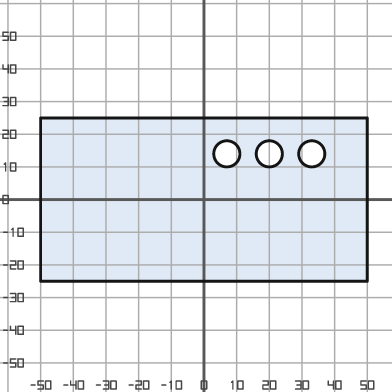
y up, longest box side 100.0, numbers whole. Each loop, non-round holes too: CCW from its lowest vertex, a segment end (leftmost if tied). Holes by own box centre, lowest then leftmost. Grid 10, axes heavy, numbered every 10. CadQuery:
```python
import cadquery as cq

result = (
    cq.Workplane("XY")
    .moveTo(-50.0, -25.0)
    .lineTo(50.0, -25.0)
    .lineTo(50.0, 25.0)
    .lineTo(-50.0, 25.0)
    .close()
    .moveTo(7.0, 14.0)
    .circle(4.0)
    .moveTo(20.0, 14.0)
    .circle(4.0)
    .moveTo(33.0, 14.0)
    .circle(4.0)
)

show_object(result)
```